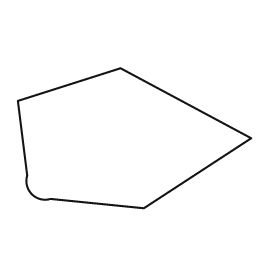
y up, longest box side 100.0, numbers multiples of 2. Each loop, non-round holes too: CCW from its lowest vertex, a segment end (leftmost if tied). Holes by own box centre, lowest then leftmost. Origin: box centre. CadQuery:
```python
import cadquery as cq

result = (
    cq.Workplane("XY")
    .moveTo(4.0, -30.0)
    .lineTo(50.0, 0.0)
    .lineTo(-6.0, 30.0)
    .lineTo(-50.0, 16.0)
    .lineTo(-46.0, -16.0)
    .threePointArc((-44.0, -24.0), (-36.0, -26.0))
    .close()
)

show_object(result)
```